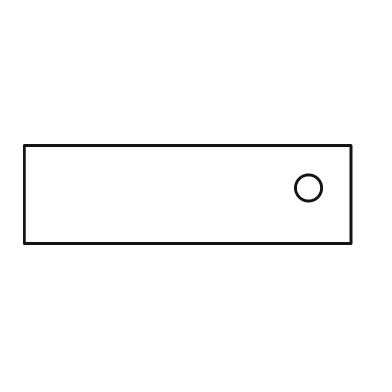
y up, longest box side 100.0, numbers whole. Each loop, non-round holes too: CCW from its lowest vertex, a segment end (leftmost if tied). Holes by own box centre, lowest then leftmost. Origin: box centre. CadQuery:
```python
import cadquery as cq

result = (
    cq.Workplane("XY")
    .moveTo(-50.0, -15.0)
    .lineTo(50.0, -15.0)
    .lineTo(50.0, 15.0)
    .lineTo(-50.0, 15.0)
    .close()
    .moveTo(37.0, 2.0)
    .circle(4.0)
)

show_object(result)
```